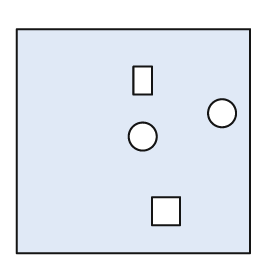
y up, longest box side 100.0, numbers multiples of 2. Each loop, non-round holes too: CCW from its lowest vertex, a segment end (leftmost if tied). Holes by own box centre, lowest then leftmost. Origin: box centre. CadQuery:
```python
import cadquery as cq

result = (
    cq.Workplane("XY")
    .moveTo(-50.0, -48.0)
    .lineTo(50.0, -48.0)
    .lineTo(50.0, 48.0)
    .lineTo(-50.0, 48.0)
    .close()
    .moveTo(8.0, -36.0)
    .lineTo(20.0, -36.0)
    .lineTo(20.0, -24.0)
    .lineTo(8.0, -24.0)
    .close()
    .moveTo(4.0, 2.0)
    .circle(6.0)
    .moveTo(38.0, 12.0)
    .circle(6.0)
    .moveTo(0.0, 20.0)
    .lineTo(8.0, 20.0)
    .lineTo(8.0, 32.0)
    .lineTo(0.0, 32.0)
    .close()
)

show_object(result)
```